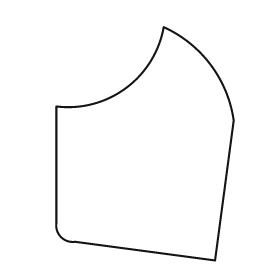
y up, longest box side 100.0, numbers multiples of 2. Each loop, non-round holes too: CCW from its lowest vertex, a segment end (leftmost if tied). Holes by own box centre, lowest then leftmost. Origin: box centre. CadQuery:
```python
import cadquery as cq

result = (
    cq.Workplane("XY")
    .moveTo(30.0, -50.0)
    .lineTo(38.0, 10.0)
    .threePointArc((28.0, 34.0), (8.0, 50.0))
    .threePointArc((-8.0, 24.0), (-38.0, 16.0))
    .lineTo(-38.0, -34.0)
    .threePointArc((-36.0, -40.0), (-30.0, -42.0))
    .close()
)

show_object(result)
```